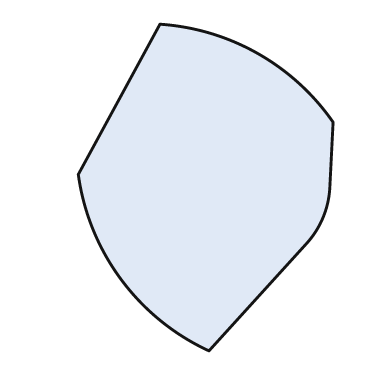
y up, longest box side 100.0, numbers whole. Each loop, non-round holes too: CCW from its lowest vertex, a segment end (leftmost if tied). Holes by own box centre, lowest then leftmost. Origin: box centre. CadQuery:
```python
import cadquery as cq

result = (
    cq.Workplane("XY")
    .moveTo(1.0, -50.0)
    .lineTo(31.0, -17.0)
    .threePointArc((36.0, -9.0), (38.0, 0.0))
    .lineTo(39.0, 20.0)
    .threePointArc((16.0, 41.0), (-14.0, 50.0))
    .lineTo(-39.0, 4.0)
    .threePointArc((-26.0, -28.0), (1.0, -50.0))
    .close()
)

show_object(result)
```